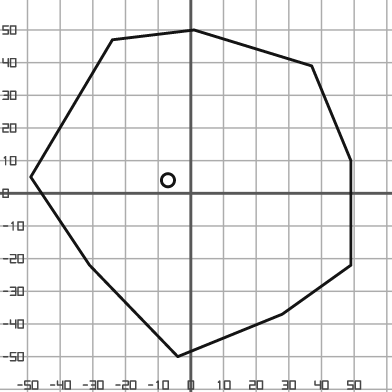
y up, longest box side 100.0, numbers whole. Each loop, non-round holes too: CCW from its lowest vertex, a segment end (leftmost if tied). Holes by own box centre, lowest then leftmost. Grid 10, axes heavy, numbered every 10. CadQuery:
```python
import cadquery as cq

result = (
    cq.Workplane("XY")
    .moveTo(-4.0, -50.0)
    .lineTo(28.0, -37.0)
    .lineTo(49.0, -22.0)
    .lineTo(49.0, 10.0)
    .lineTo(37.0, 39.0)
    .lineTo(1.0, 50.0)
    .lineTo(-24.0, 47.0)
    .lineTo(-49.0, 5.0)
    .lineTo(-31.0, -22.0)
    .close()
    .moveTo(-7.0, 4.0)
    .circle(2.0)
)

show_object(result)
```